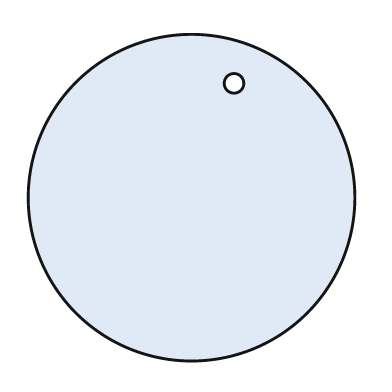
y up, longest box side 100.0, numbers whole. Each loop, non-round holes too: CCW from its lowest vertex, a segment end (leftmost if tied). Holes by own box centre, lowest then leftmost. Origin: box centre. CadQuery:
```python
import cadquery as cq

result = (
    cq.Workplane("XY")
    .moveTo(0.0, 0.0)
    .circle(50.0)
    .moveTo(13.0, 35.0)
    .circle(3.0)
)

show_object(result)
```